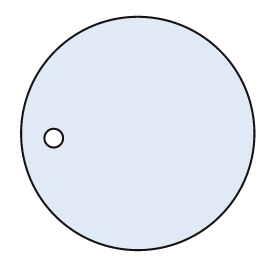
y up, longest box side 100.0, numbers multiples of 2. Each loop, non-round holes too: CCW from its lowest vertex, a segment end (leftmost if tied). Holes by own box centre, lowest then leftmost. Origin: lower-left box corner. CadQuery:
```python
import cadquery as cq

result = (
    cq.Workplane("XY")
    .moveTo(50.0, 50.0)
    .circle(50.0)
    .moveTo(14.0, 48.0)
    .circle(4.0)
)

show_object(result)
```